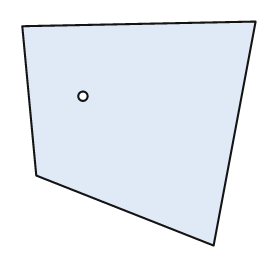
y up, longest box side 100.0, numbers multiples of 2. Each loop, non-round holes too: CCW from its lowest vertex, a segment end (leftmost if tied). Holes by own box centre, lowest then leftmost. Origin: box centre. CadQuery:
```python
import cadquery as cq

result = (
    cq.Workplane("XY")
    .moveTo(32.0, -48.0)
    .lineTo(50.0, 48.0)
    .lineTo(-50.0, 46.0)
    .lineTo(-44.0, -18.0)
    .close()
    .moveTo(-24.0, 16.0)
    .circle(2.0)
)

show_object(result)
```